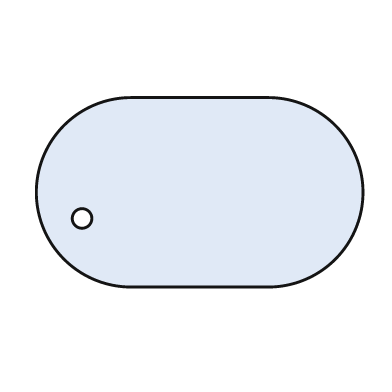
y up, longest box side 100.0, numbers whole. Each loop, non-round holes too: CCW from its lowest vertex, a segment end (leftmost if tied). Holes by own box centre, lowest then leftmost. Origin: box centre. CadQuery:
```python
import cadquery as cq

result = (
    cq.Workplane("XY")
    .moveTo(-21.0, -29.0)
    .lineTo(21.0, -29.0)
    .threePointArc((50.0, 0.0), (21.0, 29.0))
    .lineTo(-21.0, 29.0)
    .threePointArc((-50.0, 0.0), (-21.0, -29.0))
    .close()
    .moveTo(-36.0, -8.0)
    .circle(3.0)
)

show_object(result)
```